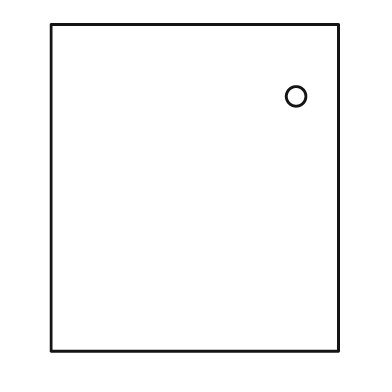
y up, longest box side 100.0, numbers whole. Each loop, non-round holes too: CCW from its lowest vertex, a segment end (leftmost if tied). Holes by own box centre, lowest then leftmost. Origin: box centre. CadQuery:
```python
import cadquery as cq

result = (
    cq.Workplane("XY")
    .moveTo(-44.0, -50.0)
    .lineTo(44.0, -50.0)
    .lineTo(44.0, 50.0)
    .lineTo(-44.0, 50.0)
    .close()
    .moveTo(31.0, 28.0)
    .circle(3.0)
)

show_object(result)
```